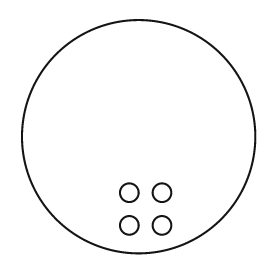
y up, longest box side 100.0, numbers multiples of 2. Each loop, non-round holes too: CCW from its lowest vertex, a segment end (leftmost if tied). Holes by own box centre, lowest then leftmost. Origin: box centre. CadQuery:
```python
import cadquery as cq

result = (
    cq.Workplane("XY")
    .moveTo(0.0, 0.0)
    .circle(50.0)
    .moveTo(-4.0, -38.0)
    .circle(4.0)
    .moveTo(10.0, -38.0)
    .circle(4.0)
    .moveTo(-4.0, -24.0)
    .circle(4.0)
    .moveTo(10.0, -24.0)
    .circle(4.0)
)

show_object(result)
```